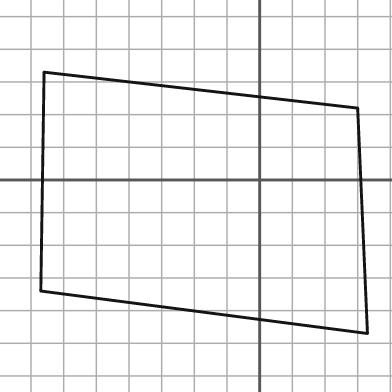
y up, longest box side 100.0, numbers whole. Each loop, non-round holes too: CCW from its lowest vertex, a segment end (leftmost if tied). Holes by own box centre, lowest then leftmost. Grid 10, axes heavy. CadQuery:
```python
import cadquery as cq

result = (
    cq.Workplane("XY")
    .moveTo(33.0, -47.0)
    .lineTo(30.0, 22.0)
    .lineTo(-66.0, 33.0)
    .lineTo(-67.0, -34.0)
    .close()
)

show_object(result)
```